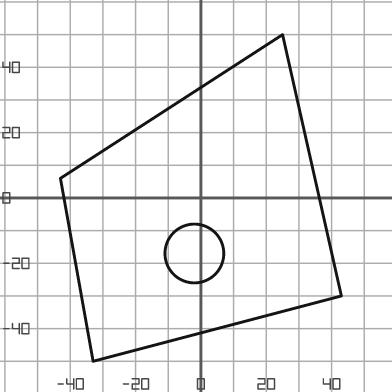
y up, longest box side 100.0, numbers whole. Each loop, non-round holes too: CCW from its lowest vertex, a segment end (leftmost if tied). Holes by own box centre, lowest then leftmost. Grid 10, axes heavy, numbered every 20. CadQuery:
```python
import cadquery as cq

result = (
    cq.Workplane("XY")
    .moveTo(-33.0, -50.0)
    .lineTo(43.0, -30.0)
    .lineTo(25.0, 50.0)
    .lineTo(-43.0, 6.0)
    .close()
    .moveTo(-2.0, -17.0)
    .circle(9.0)
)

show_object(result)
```